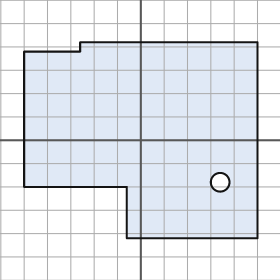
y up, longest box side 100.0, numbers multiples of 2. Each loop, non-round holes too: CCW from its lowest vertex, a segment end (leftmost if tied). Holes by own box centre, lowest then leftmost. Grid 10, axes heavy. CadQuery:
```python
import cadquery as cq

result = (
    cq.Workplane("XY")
    .moveTo(-6.0, -42.0)
    .lineTo(50.0, -42.0)
    .lineTo(50.0, 42.0)
    .lineTo(-26.0, 42.0)
    .lineTo(-26.0, 38.0)
    .lineTo(-50.0, 38.0)
    .lineTo(-50.0, -20.0)
    .lineTo(-6.0, -20.0)
    .close()
    .moveTo(34.0, -18.0)
    .circle(4.0)
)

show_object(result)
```